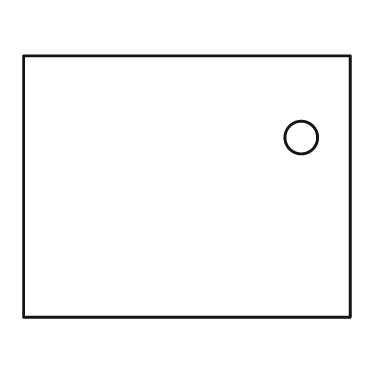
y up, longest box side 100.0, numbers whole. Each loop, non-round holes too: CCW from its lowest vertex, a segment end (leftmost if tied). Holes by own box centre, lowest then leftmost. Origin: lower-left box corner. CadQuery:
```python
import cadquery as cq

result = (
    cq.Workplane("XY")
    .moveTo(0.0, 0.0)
    .lineTo(100.0, 0.0)
    .lineTo(100.0, 80.0)
    .lineTo(0.0, 80.0)
    .close()
    .moveTo(85.0, 55.0)
    .circle(5.0)
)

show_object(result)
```